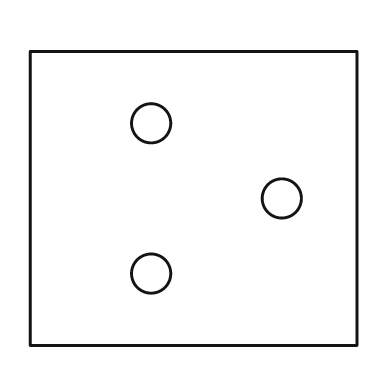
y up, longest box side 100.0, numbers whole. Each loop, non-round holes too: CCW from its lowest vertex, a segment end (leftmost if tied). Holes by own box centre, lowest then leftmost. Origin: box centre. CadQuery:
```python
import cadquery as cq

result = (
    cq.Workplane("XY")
    .moveTo(-50.0, -45.0)
    .lineTo(50.0, -45.0)
    .lineTo(50.0, 45.0)
    .lineTo(-50.0, 45.0)
    .close()
    .moveTo(-13.0, -23.0)
    .circle(6.0)
    .moveTo(27.0, 0.0)
    .circle(6.0)
    .moveTo(-13.0, 23.0)
    .circle(6.0)
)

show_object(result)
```